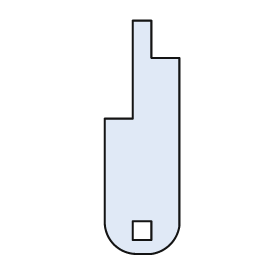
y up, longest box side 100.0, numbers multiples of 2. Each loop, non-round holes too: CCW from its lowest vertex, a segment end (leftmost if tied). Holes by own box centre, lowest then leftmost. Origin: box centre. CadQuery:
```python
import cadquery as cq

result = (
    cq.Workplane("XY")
    .moveTo(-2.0, -50.0)
    .lineTo(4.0, -50.0)
    .threePointArc((12.0, -46.0), (16.0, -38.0))
    .lineTo(16.0, 34.0)
    .lineTo(4.0, 34.0)
    .lineTo(4.0, 50.0)
    .lineTo(-4.0, 50.0)
    .lineTo(-4.0, 8.0)
    .lineTo(-16.0, 8.0)
    .lineTo(-16.0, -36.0)
    .threePointArc((-12.0, -46.0), (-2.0, -50.0))
    .close()
    .moveTo(-4.0, -44.0)
    .lineTo(4.0, -44.0)
    .lineTo(4.0, -36.0)
    .lineTo(-4.0, -36.0)
    .close()
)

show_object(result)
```